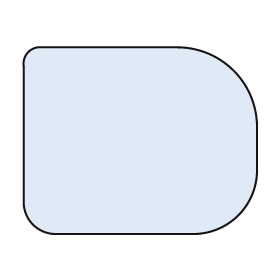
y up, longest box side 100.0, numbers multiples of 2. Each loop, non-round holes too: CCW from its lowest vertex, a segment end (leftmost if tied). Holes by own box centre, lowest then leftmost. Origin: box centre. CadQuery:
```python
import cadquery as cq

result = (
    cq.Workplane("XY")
    .moveTo(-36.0, -40.0)
    .lineTo(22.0, -40.0)
    .threePointArc((42.0, -32.0), (50.0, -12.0))
    .lineTo(50.0, 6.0)
    .threePointArc((40.0, 30.0), (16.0, 40.0))
    .lineTo(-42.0, 40.0)
    .threePointArc((-48.0, 38.0), (-50.0, 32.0))
    .lineTo(-50.0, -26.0)
    .threePointArc((-46.0, -36.0), (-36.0, -40.0))
    .close()
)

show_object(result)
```